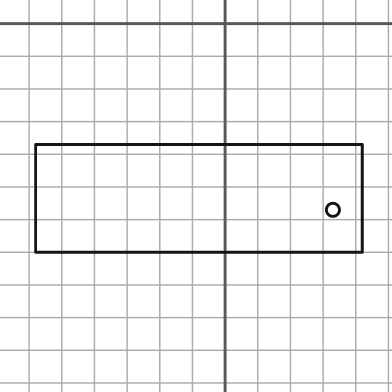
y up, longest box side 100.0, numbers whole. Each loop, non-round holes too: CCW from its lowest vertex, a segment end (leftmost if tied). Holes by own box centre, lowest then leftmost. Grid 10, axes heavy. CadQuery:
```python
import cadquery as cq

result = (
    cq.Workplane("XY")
    .moveTo(-58.0, -70.0)
    .lineTo(42.0, -70.0)
    .lineTo(42.0, -37.0)
    .lineTo(-58.0, -37.0)
    .close()
    .moveTo(33.0, -57.0)
    .circle(2.0)
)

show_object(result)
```